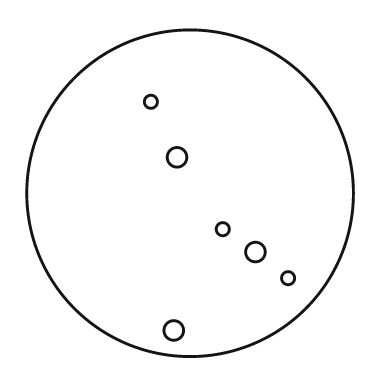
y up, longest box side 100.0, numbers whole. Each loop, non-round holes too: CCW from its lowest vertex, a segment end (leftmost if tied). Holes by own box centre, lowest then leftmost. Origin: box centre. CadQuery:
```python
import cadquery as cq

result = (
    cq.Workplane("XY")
    .moveTo(0.0, 0.0)
    .circle(50.0)
    .moveTo(-5.0, -42.0)
    .circle(3.0)
    .moveTo(30.0, -26.0)
    .circle(2.0)
    .moveTo(20.0, -18.0)
    .circle(3.0)
    .moveTo(10.0, -11.0)
    .circle(2.0)
    .moveTo(-4.0, 11.0)
    .circle(3.0)
    .moveTo(-12.0, 28.0)
    .circle(2.0)
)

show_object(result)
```